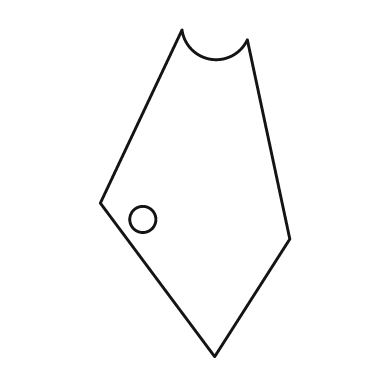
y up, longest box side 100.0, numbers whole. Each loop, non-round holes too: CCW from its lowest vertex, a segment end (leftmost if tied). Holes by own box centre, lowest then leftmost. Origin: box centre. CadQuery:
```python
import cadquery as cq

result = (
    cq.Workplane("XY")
    .moveTo(6.0, -50.0)
    .lineTo(29.0, -14.0)
    .lineTo(16.0, 47.0)
    .threePointArc((5.0, 41.0), (-4.0, 50.0))
    .lineTo(-29.0, -3.0)
    .close()
    .moveTo(-16.0, -8.0)
    .circle(4.0)
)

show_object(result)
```